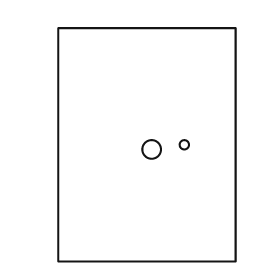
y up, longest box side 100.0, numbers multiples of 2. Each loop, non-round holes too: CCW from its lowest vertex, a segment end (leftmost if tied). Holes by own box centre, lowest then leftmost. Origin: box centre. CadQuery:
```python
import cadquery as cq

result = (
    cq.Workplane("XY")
    .moveTo(-38.0, -50.0)
    .lineTo(38.0, -50.0)
    .lineTo(38.0, 50.0)
    .lineTo(-38.0, 50.0)
    .close()
    .moveTo(2.0, -2.0)
    .circle(4.0)
    .moveTo(16.0, 0.0)
    .circle(2.0)
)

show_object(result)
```